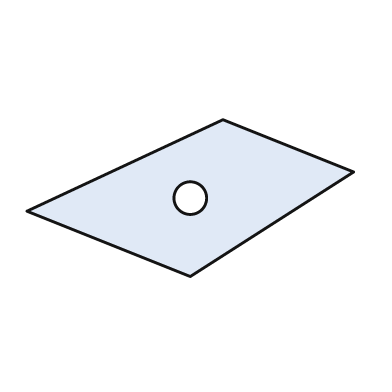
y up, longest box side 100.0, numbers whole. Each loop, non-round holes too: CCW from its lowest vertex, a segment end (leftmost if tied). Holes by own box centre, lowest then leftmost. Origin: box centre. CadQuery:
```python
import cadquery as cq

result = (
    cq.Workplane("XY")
    .moveTo(0.0, -24.0)
    .lineTo(50.0, 8.0)
    .lineTo(10.0, 24.0)
    .lineTo(-50.0, -4.0)
    .close()
    .moveTo(0.0, 0.0)
    .circle(5.0)
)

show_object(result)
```